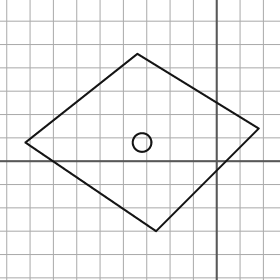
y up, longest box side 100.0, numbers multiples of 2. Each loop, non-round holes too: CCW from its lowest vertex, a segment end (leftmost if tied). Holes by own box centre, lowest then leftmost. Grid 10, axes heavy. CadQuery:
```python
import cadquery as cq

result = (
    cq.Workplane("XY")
    .moveTo(-26.0, -30.0)
    .lineTo(18.0, 14.0)
    .lineTo(-34.0, 46.0)
    .lineTo(-82.0, 8.0)
    .close()
    .moveTo(-32.0, 8.0)
    .circle(4.0)
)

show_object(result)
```